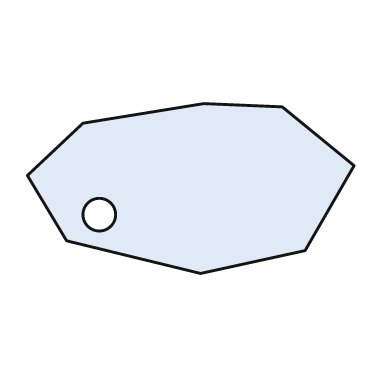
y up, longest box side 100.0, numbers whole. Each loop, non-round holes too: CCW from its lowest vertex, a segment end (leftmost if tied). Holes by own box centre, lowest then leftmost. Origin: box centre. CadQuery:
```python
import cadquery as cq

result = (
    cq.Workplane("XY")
    .moveTo(3.0, -26.0)
    .lineTo(35.0, -19.0)
    .lineTo(50.0, 7.0)
    .lineTo(28.0, 25.0)
    .lineTo(4.0, 26.0)
    .lineTo(-33.0, 20.0)
    .lineTo(-50.0, 4.0)
    .lineTo(-38.0, -16.0)
    .close()
    .moveTo(-28.0, -8.0)
    .circle(5.0)
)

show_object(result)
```